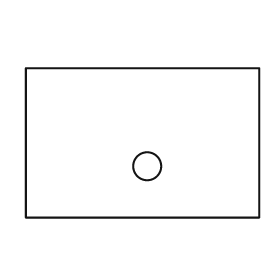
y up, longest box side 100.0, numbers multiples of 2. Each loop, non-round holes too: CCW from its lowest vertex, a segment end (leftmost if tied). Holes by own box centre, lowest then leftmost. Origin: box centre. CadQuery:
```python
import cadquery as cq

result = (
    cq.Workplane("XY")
    .moveTo(-50.0, -32.0)
    .lineTo(50.0, -32.0)
    .lineTo(50.0, 32.0)
    .lineTo(-50.0, 32.0)
    .close()
    .moveTo(2.0, -10.0)
    .circle(6.0)
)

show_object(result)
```